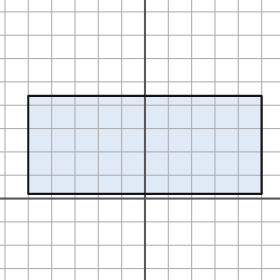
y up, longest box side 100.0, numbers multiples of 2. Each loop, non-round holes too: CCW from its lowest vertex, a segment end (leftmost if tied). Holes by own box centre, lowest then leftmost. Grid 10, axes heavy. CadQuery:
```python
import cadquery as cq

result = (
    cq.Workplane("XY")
    .moveTo(-50.0, 2.0)
    .lineTo(50.0, 2.0)
    .lineTo(50.0, 44.0)
    .lineTo(-50.0, 44.0)
    .close()
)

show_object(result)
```